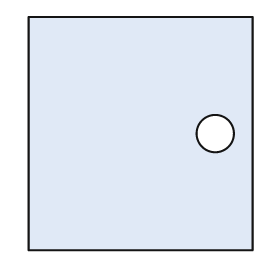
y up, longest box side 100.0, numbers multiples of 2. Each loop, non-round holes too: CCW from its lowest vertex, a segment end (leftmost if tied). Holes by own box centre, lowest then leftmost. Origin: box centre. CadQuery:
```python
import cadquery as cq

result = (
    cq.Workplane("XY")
    .moveTo(-48.0, -50.0)
    .lineTo(48.0, -50.0)
    .lineTo(48.0, 50.0)
    .lineTo(-48.0, 50.0)
    .close()
    .moveTo(32.0, 0.0)
    .circle(8.0)
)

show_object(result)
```